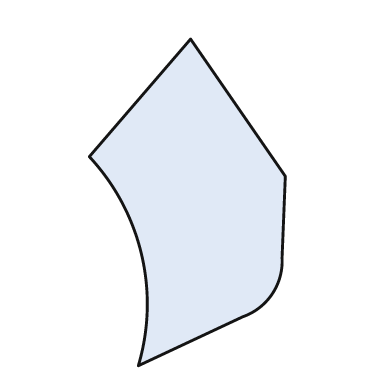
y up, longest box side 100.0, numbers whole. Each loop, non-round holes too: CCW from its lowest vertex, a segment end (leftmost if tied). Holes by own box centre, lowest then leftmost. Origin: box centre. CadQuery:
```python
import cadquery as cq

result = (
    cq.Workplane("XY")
    .moveTo(-15.0, -50.0)
    .lineTo(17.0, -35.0)
    .threePointArc((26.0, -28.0), (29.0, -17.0))
    .lineTo(30.0, 8.0)
    .lineTo(1.0, 50.0)
    .lineTo(-30.0, 14.0)
    .threePointArc((-14.0, -16.0), (-15.0, -50.0))
    .close()
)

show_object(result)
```